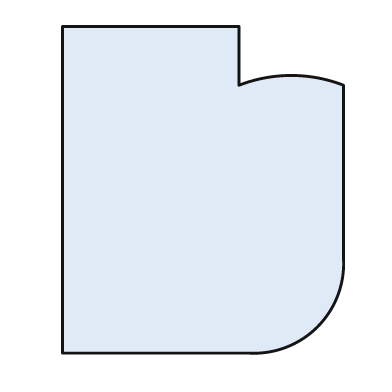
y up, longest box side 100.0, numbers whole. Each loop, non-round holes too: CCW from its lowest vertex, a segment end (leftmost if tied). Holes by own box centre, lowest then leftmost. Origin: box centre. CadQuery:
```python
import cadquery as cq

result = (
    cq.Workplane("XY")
    .moveTo(-43.0, -50.0)
    .lineTo(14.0, -50.0)
    .threePointArc((35.0, -42.0), (43.0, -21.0))
    .lineTo(43.0, 32.0)
    .threePointArc((27.0, 35.0), (11.0, 32.0))
    .lineTo(11.0, 50.0)
    .lineTo(-43.0, 50.0)
    .close()
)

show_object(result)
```